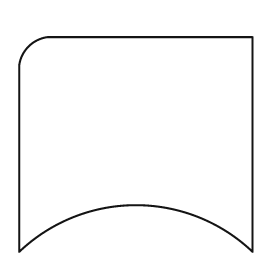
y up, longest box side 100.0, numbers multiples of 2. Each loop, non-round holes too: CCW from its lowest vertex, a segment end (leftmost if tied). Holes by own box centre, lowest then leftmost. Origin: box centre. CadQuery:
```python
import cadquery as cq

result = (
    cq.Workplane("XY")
    .moveTo(-50.0, -46.0)
    .threePointArc((0.0, -26.0), (50.0, -46.0))
    .lineTo(50.0, 46.0)
    .lineTo(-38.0, 46.0)
    .threePointArc((-46.0, 42.0), (-50.0, 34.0))
    .close()
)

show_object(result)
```